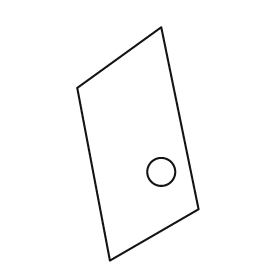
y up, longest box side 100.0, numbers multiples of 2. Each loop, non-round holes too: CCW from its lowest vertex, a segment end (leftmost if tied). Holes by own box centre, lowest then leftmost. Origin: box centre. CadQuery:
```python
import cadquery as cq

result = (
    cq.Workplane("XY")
    .moveTo(-12.0, -50.0)
    .lineTo(26.0, -28.0)
    .lineTo(10.0, 50.0)
    .lineTo(-26.0, 24.0)
    .close()
    .moveTo(10.0, -12.0)
    .circle(6.0)
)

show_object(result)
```